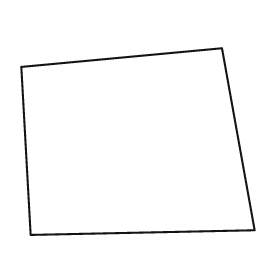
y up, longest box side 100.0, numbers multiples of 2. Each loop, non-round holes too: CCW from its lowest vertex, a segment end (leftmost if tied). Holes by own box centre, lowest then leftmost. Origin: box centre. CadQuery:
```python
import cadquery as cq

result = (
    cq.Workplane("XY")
    .moveTo(-46.0, -40.0)
    .lineTo(50.0, -38.0)
    .lineTo(36.0, 40.0)
    .lineTo(-50.0, 32.0)
    .close()
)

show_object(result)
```